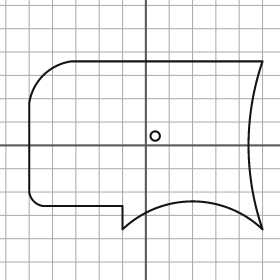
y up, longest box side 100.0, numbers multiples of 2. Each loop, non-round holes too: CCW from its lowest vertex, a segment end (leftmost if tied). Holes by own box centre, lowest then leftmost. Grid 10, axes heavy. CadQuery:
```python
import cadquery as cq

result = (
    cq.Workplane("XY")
    .moveTo(-10.0, -36.0)
    .threePointArc((20.0, -24.0), (50.0, -36.0))
    .threePointArc((44.0, 0.0), (50.0, 36.0))
    .lineTo(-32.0, 36.0)
    .threePointArc((-44.0, 30.0), (-50.0, 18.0))
    .lineTo(-50.0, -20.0)
    .threePointArc((-48.0, -24.0), (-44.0, -26.0))
    .lineTo(-10.0, -26.0)
    .close()
    .moveTo(4.0, 4.0)
    .circle(2.0)
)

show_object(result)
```